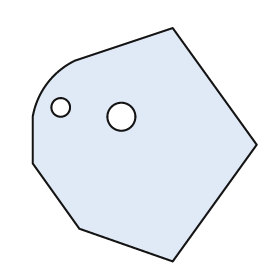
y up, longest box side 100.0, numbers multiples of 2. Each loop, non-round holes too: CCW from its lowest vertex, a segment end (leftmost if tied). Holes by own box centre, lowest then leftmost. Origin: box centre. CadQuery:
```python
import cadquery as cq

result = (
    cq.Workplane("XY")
    .moveTo(12.0, -50.0)
    .lineTo(48.0, 0.0)
    .lineTo(12.0, 50.0)
    .lineTo(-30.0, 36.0)
    .threePointArc((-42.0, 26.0), (-48.0, 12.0))
    .lineTo(-48.0, -8.0)
    .lineTo(-28.0, -36.0)
    .close()
    .moveTo(-10.0, 12.0)
    .circle(6.0)
    .moveTo(-36.0, 16.0)
    .circle(4.0)
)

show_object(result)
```